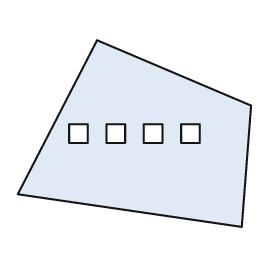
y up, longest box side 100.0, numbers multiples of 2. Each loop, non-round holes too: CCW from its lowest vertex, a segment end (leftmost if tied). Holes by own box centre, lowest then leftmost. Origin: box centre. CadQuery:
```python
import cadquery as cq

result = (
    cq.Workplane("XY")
    .moveTo(46.0, -40.0)
    .lineTo(50.0, 12.0)
    .lineTo(-16.0, 40.0)
    .lineTo(-50.0, -26.0)
    .close()
    .moveTo(-28.0, -4.0)
    .lineTo(-20.0, -4.0)
    .lineTo(-20.0, 4.0)
    .lineTo(-28.0, 4.0)
    .close()
    .moveTo(-12.0, -4.0)
    .lineTo(-4.0, -4.0)
    .lineTo(-4.0, 4.0)
    .lineTo(-12.0, 4.0)
    .close()
    .moveTo(4.0, -4.0)
    .lineTo(12.0, -4.0)
    .lineTo(12.0, 4.0)
    .lineTo(4.0, 4.0)
    .close()
    .moveTo(20.0, -4.0)
    .lineTo(28.0, -4.0)
    .lineTo(28.0, 4.0)
    .lineTo(20.0, 4.0)
    .close()
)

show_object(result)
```